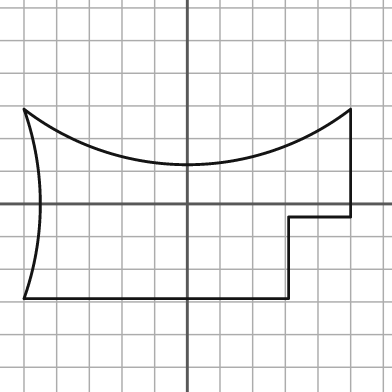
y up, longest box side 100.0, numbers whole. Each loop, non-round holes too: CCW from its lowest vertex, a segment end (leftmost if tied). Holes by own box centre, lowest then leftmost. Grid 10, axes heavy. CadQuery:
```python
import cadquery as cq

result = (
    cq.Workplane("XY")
    .moveTo(-50.0, -29.0)
    .lineTo(31.0, -29.0)
    .lineTo(31.0, -4.0)
    .lineTo(50.0, -4.0)
    .lineTo(50.0, 29.0)
    .threePointArc((0.0, 12.0), (-50.0, 29.0))
    .threePointArc((-45.0, 0.0), (-50.0, -29.0))
    .close()
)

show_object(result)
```